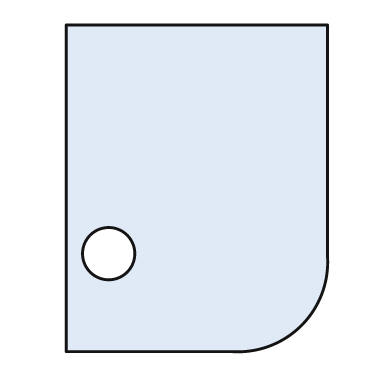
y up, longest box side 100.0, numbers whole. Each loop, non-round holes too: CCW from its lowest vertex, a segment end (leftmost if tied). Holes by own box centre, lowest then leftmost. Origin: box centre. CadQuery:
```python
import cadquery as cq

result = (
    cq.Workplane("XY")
    .moveTo(-40.0, -50.0)
    .lineTo(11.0, -50.0)
    .threePointArc((32.0, -42.0), (40.0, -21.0))
    .lineTo(40.0, 50.0)
    .lineTo(-40.0, 50.0)
    .close()
    .moveTo(-27.0, -20.0)
    .circle(8.0)
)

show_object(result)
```